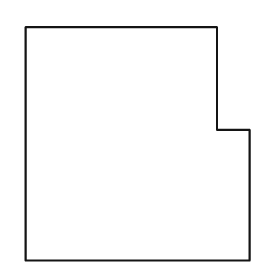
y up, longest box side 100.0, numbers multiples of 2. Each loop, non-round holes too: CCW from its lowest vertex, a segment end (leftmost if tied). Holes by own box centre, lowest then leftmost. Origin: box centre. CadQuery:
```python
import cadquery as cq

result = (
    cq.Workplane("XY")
    .moveTo(-48.0, -50.0)
    .lineTo(48.0, -50.0)
    .lineTo(48.0, 6.0)
    .lineTo(34.0, 6.0)
    .lineTo(34.0, 50.0)
    .lineTo(-48.0, 50.0)
    .close()
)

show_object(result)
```